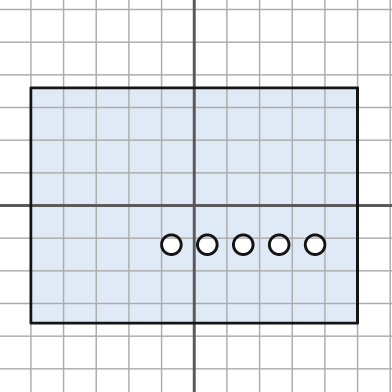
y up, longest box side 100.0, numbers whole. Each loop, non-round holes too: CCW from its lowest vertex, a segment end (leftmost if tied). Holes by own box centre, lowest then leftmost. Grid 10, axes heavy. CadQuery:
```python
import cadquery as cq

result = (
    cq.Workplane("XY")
    .moveTo(-50.0, -36.0)
    .lineTo(50.0, -36.0)
    .lineTo(50.0, 36.0)
    .lineTo(-50.0, 36.0)
    .close()
    .moveTo(-7.0, -12.0)
    .circle(3.0)
    .moveTo(4.0, -12.0)
    .circle(3.0)
    .moveTo(15.0, -12.0)
    .circle(3.0)
    .moveTo(26.0, -12.0)
    .circle(3.0)
    .moveTo(37.0, -12.0)
    .circle(3.0)
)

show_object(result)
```